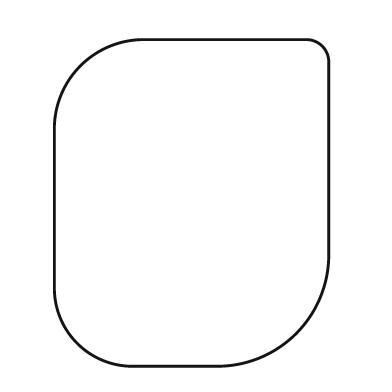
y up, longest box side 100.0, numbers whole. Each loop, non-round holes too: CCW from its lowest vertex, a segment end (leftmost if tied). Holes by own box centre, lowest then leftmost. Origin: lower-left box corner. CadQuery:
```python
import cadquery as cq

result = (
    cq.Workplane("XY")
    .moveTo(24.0, 0.0)
    .lineTo(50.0, 0.0)
    .threePointArc((74.0, 10.0), (84.0, 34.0))
    .lineTo(84.0, 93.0)
    .threePointArc((82.0, 98.0), (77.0, 100.0))
    .lineTo(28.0, 100.0)
    .threePointArc((8.0, 92.0), (0.0, 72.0))
    .lineTo(0.0, 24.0)
    .threePointArc((7.0, 7.0), (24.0, 0.0))
    .close()
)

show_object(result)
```